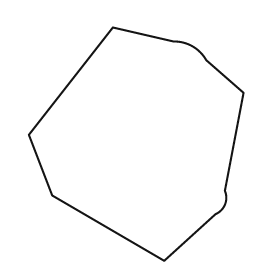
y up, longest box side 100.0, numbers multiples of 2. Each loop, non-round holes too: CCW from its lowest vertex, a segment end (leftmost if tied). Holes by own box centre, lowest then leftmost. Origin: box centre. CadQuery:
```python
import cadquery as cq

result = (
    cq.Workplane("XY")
    .moveTo(12.0, -50.0)
    .lineTo(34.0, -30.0)
    .threePointArc((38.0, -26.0), (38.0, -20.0))
    .lineTo(46.0, 22.0)
    .lineTo(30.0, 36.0)
    .threePointArc((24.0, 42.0), (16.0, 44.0))
    .lineTo(-10.0, 50.0)
    .lineTo(-46.0, 4.0)
    .lineTo(-36.0, -22.0)
    .close()
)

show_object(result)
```